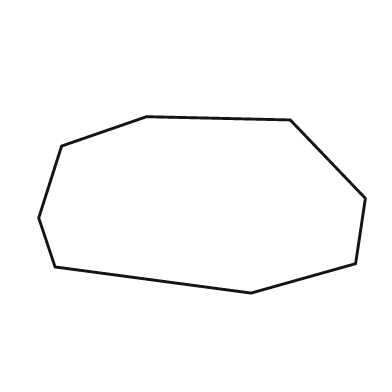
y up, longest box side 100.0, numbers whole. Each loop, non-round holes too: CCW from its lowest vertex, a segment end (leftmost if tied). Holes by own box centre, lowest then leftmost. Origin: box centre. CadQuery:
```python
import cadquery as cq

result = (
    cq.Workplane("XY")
    .moveTo(15.0, -27.0)
    .lineTo(47.0, -18.0)
    .lineTo(50.0, 2.0)
    .lineTo(27.0, 26.0)
    .lineTo(-17.0, 27.0)
    .lineTo(-43.0, 18.0)
    .lineTo(-50.0, -4.0)
    .lineTo(-45.0, -19.0)
    .close()
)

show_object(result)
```